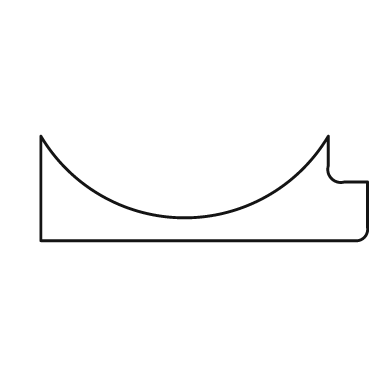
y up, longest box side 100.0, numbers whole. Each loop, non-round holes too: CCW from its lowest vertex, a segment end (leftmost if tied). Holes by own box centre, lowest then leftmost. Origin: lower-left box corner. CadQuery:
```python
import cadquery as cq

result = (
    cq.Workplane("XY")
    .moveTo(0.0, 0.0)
    .lineTo(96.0, 0.0)
    .threePointArc((99.0, 1.0), (100.0, 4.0))
    .lineTo(100.0, 18.0)
    .lineTo(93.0, 18.0)
    .threePointArc((89.0, 19.0), (88.0, 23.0))
    .lineTo(88.0, 32.0)
    .threePointArc((44.0, 7.0), (0.0, 32.0))
    .close()
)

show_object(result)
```